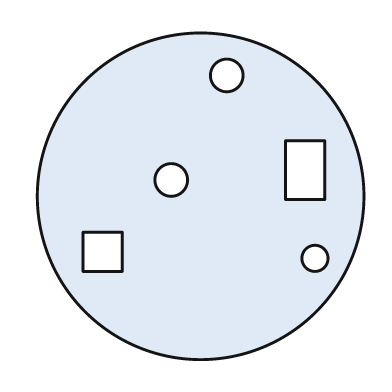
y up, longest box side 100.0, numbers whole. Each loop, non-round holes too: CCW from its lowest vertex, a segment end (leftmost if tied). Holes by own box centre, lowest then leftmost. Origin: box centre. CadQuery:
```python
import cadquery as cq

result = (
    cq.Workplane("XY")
    .moveTo(0.0, 0.0)
    .circle(50.0)
    .moveTo(35.0, -19.0)
    .circle(4.0)
    .moveTo(-36.0, -23.0)
    .lineTo(-24.0, -23.0)
    .lineTo(-24.0, -11.0)
    .lineTo(-36.0, -11.0)
    .close()
    .moveTo(-9.0, 5.0)
    .circle(5.0)
    .moveTo(26.0, -1.0)
    .lineTo(38.0, -1.0)
    .lineTo(38.0, 17.0)
    .lineTo(26.0, 17.0)
    .close()
    .moveTo(8.0, 37.0)
    .circle(5.0)
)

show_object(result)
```